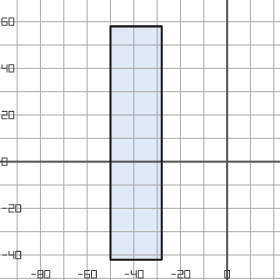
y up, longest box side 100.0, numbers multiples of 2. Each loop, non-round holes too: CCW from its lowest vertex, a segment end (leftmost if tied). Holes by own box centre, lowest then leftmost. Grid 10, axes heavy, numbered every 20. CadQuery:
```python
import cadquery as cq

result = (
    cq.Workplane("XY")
    .moveTo(-50.0, -42.0)
    .lineTo(-28.0, -42.0)
    .lineTo(-28.0, 58.0)
    .lineTo(-50.0, 58.0)
    .close()
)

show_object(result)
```